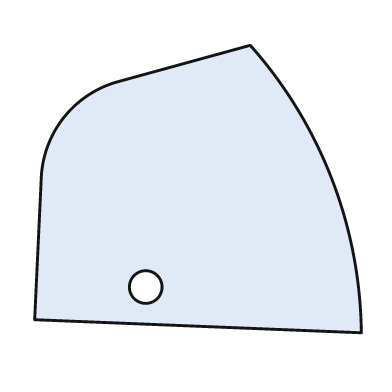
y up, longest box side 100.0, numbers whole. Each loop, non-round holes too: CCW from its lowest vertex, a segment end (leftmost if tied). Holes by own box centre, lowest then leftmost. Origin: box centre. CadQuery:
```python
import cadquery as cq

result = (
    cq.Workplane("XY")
    .moveTo(50.0, -44.0)
    .threePointArc((41.0, 3.0), (16.0, 44.0))
    .lineTo(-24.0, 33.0)
    .threePointArc((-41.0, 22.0), (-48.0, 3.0))
    .lineTo(-50.0, -40.0)
    .close()
    .moveTo(-16.0, -30.0)
    .circle(5.0)
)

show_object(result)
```